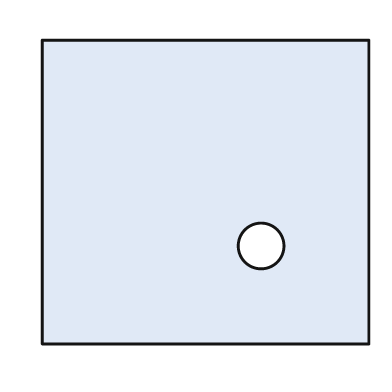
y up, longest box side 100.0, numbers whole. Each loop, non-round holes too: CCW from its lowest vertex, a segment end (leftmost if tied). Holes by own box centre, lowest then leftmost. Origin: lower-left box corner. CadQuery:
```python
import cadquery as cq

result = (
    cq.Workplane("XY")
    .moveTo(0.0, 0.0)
    .lineTo(100.0, 0.0)
    .lineTo(100.0, 93.0)
    .lineTo(0.0, 93.0)
    .close()
    .moveTo(67.0, 30.0)
    .circle(7.0)
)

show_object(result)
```